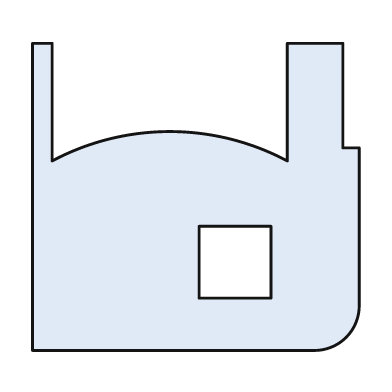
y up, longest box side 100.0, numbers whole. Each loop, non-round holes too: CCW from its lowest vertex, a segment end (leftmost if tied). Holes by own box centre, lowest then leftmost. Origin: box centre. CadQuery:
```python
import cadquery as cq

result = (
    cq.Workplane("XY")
    .moveTo(-50.0, -47.0)
    .lineTo(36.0, -47.0)
    .threePointArc((46.0, -43.0), (50.0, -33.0))
    .lineTo(50.0, 15.0)
    .lineTo(45.0, 15.0)
    .lineTo(45.0, 47.0)
    .lineTo(28.0, 47.0)
    .lineTo(28.0, 11.0)
    .threePointArc((-8.0, 20.0), (-44.0, 11.0))
    .lineTo(-44.0, 47.0)
    .lineTo(-50.0, 47.0)
    .close()
    .moveTo(1.0, -31.0)
    .lineTo(23.0, -31.0)
    .lineTo(23.0, -9.0)
    .lineTo(1.0, -9.0)
    .close()
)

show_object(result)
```